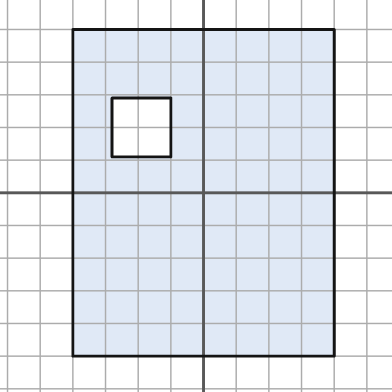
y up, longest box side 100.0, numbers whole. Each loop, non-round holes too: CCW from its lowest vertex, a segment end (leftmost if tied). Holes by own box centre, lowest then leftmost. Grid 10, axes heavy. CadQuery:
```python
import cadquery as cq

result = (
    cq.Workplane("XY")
    .moveTo(-40.0, -50.0)
    .lineTo(40.0, -50.0)
    .lineTo(40.0, 50.0)
    .lineTo(-40.0, 50.0)
    .close()
    .moveTo(-28.0, 11.0)
    .lineTo(-10.0, 11.0)
    .lineTo(-10.0, 29.0)
    .lineTo(-28.0, 29.0)
    .close()
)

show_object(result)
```